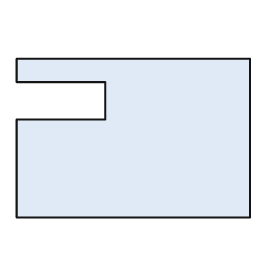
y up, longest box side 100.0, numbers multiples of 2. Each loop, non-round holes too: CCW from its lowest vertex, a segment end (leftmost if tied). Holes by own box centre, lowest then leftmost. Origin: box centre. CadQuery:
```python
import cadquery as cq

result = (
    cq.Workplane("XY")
    .moveTo(-50.0, -34.0)
    .lineTo(50.0, -34.0)
    .lineTo(50.0, 34.0)
    .lineTo(-50.0, 34.0)
    .lineTo(-50.0, 24.0)
    .lineTo(-12.0, 24.0)
    .lineTo(-12.0, 8.0)
    .lineTo(-50.0, 8.0)
    .close()
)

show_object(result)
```